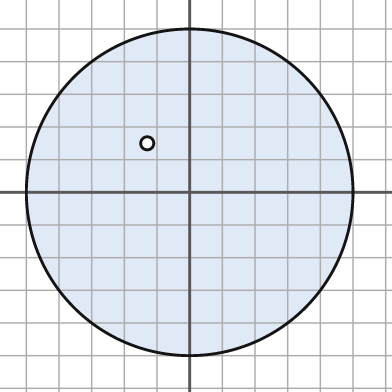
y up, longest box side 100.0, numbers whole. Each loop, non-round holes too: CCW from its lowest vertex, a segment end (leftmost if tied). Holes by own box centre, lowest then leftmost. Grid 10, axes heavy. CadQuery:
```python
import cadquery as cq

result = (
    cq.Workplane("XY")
    .moveTo(0.0, 0.0)
    .circle(50.0)
    .moveTo(-13.0, 15.0)
    .circle(2.0)
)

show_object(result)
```